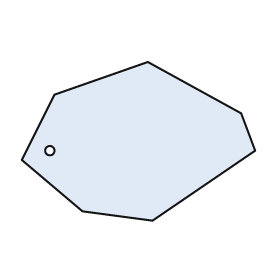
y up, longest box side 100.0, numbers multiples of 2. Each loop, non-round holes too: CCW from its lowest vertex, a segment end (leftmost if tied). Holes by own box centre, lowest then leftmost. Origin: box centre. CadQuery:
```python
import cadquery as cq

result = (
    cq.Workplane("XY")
    .moveTo(6.0, -34.0)
    .lineTo(50.0, -4.0)
    .lineTo(44.0, 12.0)
    .lineTo(4.0, 34.0)
    .lineTo(-36.0, 20.0)
    .lineTo(-50.0, -8.0)
    .lineTo(-24.0, -30.0)
    .close()
    .moveTo(-38.0, -4.0)
    .circle(2.0)
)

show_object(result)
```